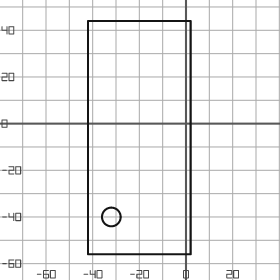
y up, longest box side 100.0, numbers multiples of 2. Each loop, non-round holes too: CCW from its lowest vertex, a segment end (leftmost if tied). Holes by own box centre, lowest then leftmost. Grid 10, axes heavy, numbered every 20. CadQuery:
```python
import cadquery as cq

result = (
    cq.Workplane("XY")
    .moveTo(-42.0, -56.0)
    .lineTo(2.0, -56.0)
    .lineTo(2.0, 44.0)
    .lineTo(-42.0, 44.0)
    .close()
    .moveTo(-32.0, -40.0)
    .circle(4.0)
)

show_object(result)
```